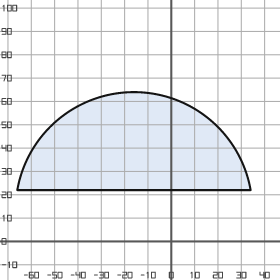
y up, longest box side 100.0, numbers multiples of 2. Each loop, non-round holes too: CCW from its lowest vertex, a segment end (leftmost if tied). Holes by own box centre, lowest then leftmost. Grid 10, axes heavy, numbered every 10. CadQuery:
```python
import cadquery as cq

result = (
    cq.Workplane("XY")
    .moveTo(-66.0, 22.0)
    .lineTo(34.0, 22.0)
    .threePointArc((-16.0, 64.0), (-66.0, 22.0))
    .close()
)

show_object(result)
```